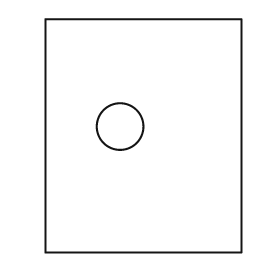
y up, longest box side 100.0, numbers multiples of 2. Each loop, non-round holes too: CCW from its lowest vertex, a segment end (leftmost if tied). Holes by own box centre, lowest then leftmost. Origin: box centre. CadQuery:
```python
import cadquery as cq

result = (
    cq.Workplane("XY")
    .moveTo(-42.0, -50.0)
    .lineTo(42.0, -50.0)
    .lineTo(42.0, 50.0)
    .lineTo(-42.0, 50.0)
    .close()
    .moveTo(-10.0, 4.0)
    .circle(10.0)
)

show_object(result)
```